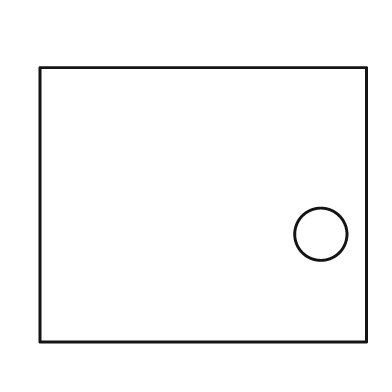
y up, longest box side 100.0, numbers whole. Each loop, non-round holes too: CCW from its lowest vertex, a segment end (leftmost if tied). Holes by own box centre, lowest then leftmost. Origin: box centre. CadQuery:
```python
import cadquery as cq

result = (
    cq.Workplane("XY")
    .moveTo(-50.0, -42.0)
    .lineTo(50.0, -42.0)
    .lineTo(50.0, 42.0)
    .lineTo(-50.0, 42.0)
    .close()
    .moveTo(36.0, -9.0)
    .circle(8.0)
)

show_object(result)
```